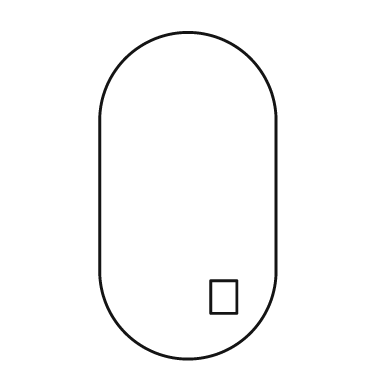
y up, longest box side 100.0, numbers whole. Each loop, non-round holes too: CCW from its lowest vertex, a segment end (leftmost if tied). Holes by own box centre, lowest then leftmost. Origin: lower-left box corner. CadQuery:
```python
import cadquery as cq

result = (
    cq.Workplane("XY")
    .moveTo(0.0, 27.0)
    .threePointArc((27.0, 0.0), (54.0, 27.0))
    .lineTo(54.0, 73.0)
    .threePointArc((27.0, 100.0), (0.0, 73.0))
    .close()
    .moveTo(34.0, 14.0)
    .lineTo(42.0, 14.0)
    .lineTo(42.0, 24.0)
    .lineTo(34.0, 24.0)
    .close()
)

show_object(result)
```